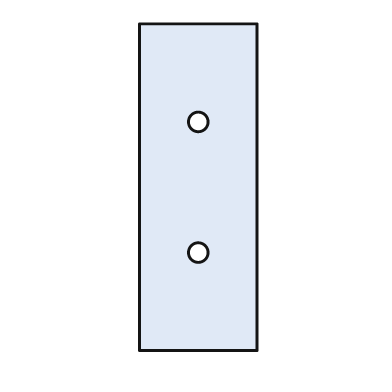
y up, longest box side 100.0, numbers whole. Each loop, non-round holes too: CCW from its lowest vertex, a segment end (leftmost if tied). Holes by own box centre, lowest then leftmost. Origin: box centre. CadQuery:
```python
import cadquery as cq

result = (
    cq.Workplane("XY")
    .moveTo(-18.0, -50.0)
    .lineTo(18.0, -50.0)
    .lineTo(18.0, 50.0)
    .lineTo(-18.0, 50.0)
    .close()
    .moveTo(0.0, -20.0)
    .circle(3.0)
    .moveTo(0.0, 20.0)
    .circle(3.0)
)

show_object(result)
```